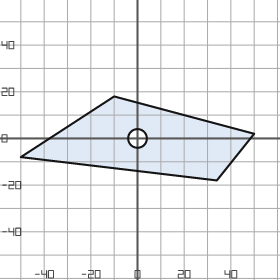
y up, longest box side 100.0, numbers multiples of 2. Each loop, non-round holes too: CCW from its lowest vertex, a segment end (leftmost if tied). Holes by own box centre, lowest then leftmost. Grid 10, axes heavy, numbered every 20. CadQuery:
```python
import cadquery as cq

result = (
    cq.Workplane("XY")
    .moveTo(34.0, -18.0)
    .lineTo(50.0, 2.0)
    .lineTo(-10.0, 18.0)
    .lineTo(-50.0, -8.0)
    .close()
    .moveTo(0.0, 0.0)
    .circle(4.0)
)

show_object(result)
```